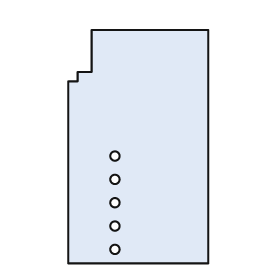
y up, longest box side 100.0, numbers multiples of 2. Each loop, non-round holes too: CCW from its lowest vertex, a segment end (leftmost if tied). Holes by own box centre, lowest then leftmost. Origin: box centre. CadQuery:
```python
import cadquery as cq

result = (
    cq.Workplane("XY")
    .moveTo(-30.0, -50.0)
    .lineTo(30.0, -50.0)
    .lineTo(30.0, 50.0)
    .lineTo(-20.0, 50.0)
    .lineTo(-20.0, 32.0)
    .lineTo(-26.0, 32.0)
    .lineTo(-26.0, 28.0)
    .lineTo(-30.0, 28.0)
    .close()
    .moveTo(-10.0, -44.0)
    .circle(2.0)
    .moveTo(-10.0, -34.0)
    .circle(2.0)
    .moveTo(-10.0, -24.0)
    .circle(2.0)
    .moveTo(-10.0, -14.0)
    .circle(2.0)
    .moveTo(-10.0, -4.0)
    .circle(2.0)
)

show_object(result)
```